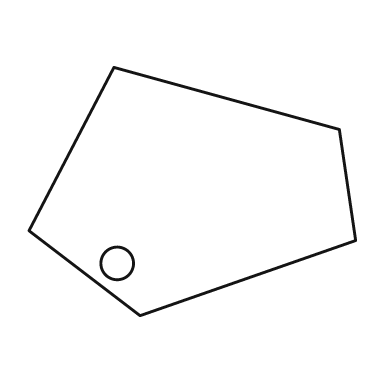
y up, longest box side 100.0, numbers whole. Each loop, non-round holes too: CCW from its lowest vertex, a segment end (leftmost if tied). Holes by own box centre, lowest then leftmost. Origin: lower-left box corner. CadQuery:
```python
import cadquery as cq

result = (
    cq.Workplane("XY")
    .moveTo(34.0, 0.0)
    .lineTo(100.0, 23.0)
    .lineTo(95.0, 57.0)
    .lineTo(26.0, 76.0)
    .lineTo(0.0, 26.0)
    .close()
    .moveTo(27.0, 16.0)
    .circle(5.0)
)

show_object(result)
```